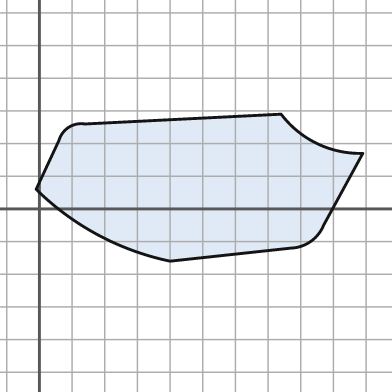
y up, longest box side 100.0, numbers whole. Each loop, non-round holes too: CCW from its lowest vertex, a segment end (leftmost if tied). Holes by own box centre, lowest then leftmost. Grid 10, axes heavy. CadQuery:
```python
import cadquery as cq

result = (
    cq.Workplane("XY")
    .moveTo(40.0, -16.0)
    .lineTo(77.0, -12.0)
    .threePointArc((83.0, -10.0), (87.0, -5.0))
    .lineTo(99.0, 17.0)
    .threePointArc((85.0, 20.0), (74.0, 29.0))
    .lineTo(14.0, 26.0)
    .threePointArc((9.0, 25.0), (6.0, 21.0))
    .lineTo(-1.0, 6.0)
    .threePointArc((18.0, -8.0), (40.0, -16.0))
    .close()
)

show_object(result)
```